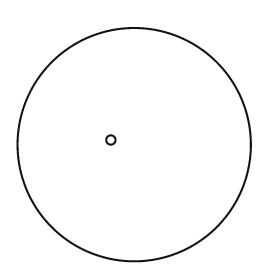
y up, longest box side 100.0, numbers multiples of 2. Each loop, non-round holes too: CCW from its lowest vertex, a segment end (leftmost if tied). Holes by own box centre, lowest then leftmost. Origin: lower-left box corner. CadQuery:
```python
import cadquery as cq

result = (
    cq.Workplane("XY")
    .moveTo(50.0, 50.0)
    .circle(50.0)
    .moveTo(40.0, 52.0)
    .circle(2.0)
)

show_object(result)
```